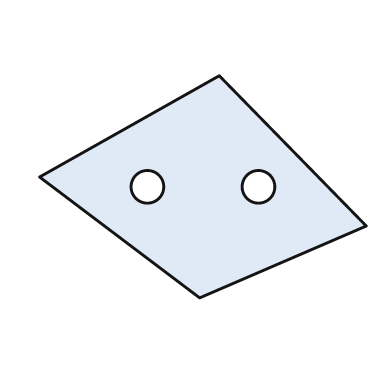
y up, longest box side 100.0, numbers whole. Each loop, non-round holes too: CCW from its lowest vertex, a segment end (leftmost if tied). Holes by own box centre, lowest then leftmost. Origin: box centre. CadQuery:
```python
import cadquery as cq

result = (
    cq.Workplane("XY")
    .moveTo(-1.0, -34.0)
    .lineTo(50.0, -12.0)
    .lineTo(5.0, 34.0)
    .lineTo(-50.0, 3.0)
    .close()
    .moveTo(-17.0, 0.0)
    .circle(5.0)
    .moveTo(17.0, 0.0)
    .circle(5.0)
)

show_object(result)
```